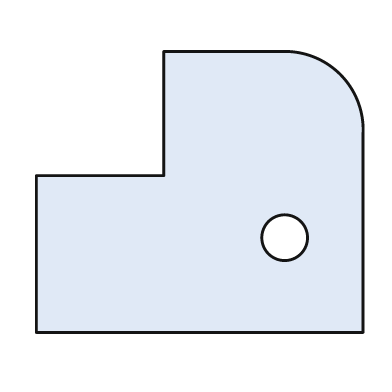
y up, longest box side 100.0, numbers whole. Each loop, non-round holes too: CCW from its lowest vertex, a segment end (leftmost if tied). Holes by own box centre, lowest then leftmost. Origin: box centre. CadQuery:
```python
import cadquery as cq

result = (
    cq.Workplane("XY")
    .moveTo(-50.0, -43.0)
    .lineTo(50.0, -43.0)
    .lineTo(50.0, 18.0)
    .threePointArc((43.0, 36.0), (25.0, 43.0))
    .lineTo(-11.0, 43.0)
    .lineTo(-11.0, 5.0)
    .lineTo(-50.0, 5.0)
    .close()
    .moveTo(26.0, -14.0)
    .circle(7.0)
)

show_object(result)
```